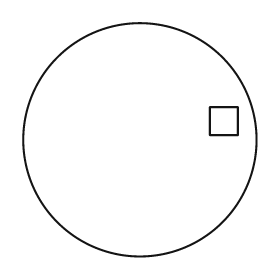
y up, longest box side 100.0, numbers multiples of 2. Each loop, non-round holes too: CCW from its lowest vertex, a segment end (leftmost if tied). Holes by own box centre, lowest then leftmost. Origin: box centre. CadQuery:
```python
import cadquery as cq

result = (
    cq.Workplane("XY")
    .moveTo(0.0, 0.0)
    .circle(50.0)
    .moveTo(30.0, 2.0)
    .lineTo(42.0, 2.0)
    .lineTo(42.0, 14.0)
    .lineTo(30.0, 14.0)
    .close()
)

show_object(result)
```